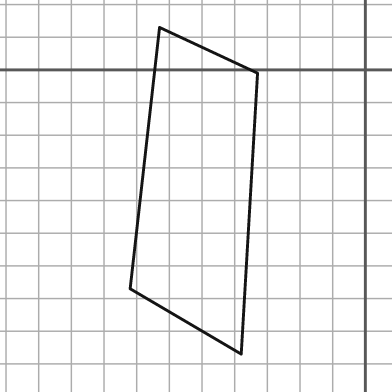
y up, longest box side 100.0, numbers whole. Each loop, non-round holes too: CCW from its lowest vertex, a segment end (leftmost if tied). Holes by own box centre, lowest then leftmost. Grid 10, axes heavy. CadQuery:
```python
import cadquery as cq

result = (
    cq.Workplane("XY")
    .moveTo(-38.0, -87.0)
    .lineTo(-33.0, -1.0)
    .lineTo(-63.0, 13.0)
    .lineTo(-72.0, -67.0)
    .close()
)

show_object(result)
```